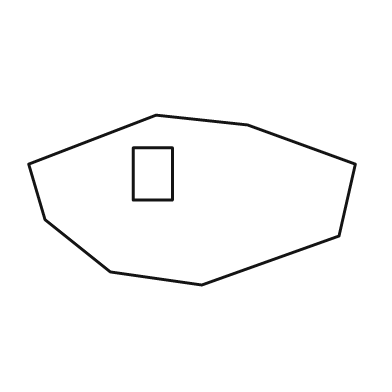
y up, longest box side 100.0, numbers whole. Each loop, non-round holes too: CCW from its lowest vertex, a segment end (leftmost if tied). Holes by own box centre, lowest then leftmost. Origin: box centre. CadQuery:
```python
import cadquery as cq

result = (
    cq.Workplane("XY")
    .moveTo(3.0, -26.0)
    .lineTo(45.0, -11.0)
    .lineTo(50.0, 11.0)
    .lineTo(17.0, 23.0)
    .lineTo(-11.0, 26.0)
    .lineTo(-50.0, 11.0)
    .lineTo(-45.0, -6.0)
    .lineTo(-25.0, -22.0)
    .close()
    .moveTo(-18.0, 0.0)
    .lineTo(-6.0, 0.0)
    .lineTo(-6.0, 16.0)
    .lineTo(-18.0, 16.0)
    .close()
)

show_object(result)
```